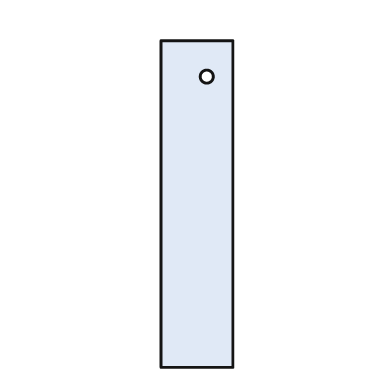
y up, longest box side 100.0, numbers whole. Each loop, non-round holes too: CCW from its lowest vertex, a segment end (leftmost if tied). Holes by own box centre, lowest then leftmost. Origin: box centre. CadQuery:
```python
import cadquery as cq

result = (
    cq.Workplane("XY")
    .moveTo(-11.0, -50.0)
    .lineTo(11.0, -50.0)
    .lineTo(11.0, 50.0)
    .lineTo(-11.0, 50.0)
    .close()
    .moveTo(3.0, 39.0)
    .circle(2.0)
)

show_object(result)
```